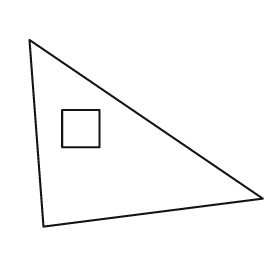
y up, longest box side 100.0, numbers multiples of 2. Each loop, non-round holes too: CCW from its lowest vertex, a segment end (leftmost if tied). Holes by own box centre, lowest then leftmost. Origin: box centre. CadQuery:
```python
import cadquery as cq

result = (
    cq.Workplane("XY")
    .moveTo(-44.0, -40.0)
    .lineTo(50.0, -28.0)
    .lineTo(-50.0, 40.0)
    .close()
    .moveTo(-36.0, -6.0)
    .lineTo(-20.0, -6.0)
    .lineTo(-20.0, 10.0)
    .lineTo(-36.0, 10.0)
    .close()
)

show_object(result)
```